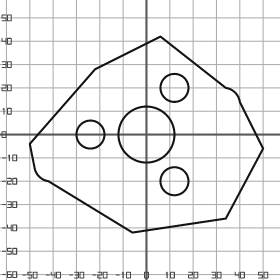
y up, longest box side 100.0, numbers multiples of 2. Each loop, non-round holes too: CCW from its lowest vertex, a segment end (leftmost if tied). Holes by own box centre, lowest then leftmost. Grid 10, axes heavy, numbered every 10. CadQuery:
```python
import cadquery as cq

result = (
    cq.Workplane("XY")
    .moveTo(-6.0, -42.0)
    .lineTo(34.0, -36.0)
    .lineTo(50.0, -6.0)
    .lineTo(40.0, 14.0)
    .threePointArc((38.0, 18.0), (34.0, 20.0))
    .lineTo(6.0, 42.0)
    .lineTo(-22.0, 28.0)
    .lineTo(-50.0, -4.0)
    .lineTo(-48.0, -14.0)
    .threePointArc((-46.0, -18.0), (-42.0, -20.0))
    .close()
    .moveTo(12.0, -20.0)
    .circle(6.0)
    .moveTo(-24.0, 0.0)
    .circle(6.0)
    .moveTo(0.0, 0.0)
    .circle(12.0)
    .moveTo(12.0, 20.0)
    .circle(6.0)
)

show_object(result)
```